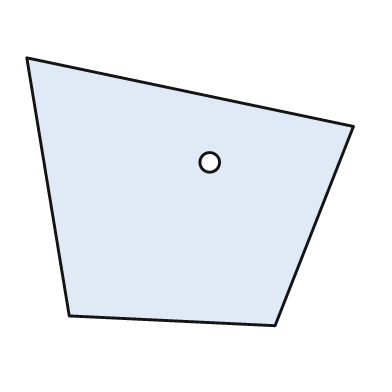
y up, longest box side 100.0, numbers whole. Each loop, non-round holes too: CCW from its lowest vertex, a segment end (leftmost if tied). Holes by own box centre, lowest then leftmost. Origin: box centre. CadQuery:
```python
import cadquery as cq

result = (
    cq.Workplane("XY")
    .moveTo(26.0, -41.0)
    .lineTo(50.0, 20.0)
    .lineTo(-50.0, 41.0)
    .lineTo(-37.0, -38.0)
    .close()
    .moveTo(6.0, 9.0)
    .circle(3.0)
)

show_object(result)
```